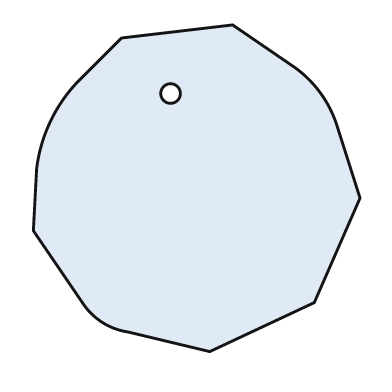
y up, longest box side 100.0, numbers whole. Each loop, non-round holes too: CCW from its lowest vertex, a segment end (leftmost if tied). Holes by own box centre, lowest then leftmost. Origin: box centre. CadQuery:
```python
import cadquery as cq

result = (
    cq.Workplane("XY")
    .moveTo(4.0, -50.0)
    .lineTo(36.0, -35.0)
    .lineTo(50.0, -3.0)
    .lineTo(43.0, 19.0)
    .threePointArc((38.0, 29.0), (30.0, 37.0))
    .lineTo(11.0, 50.0)
    .lineTo(-23.0, 46.0)
    .lineTo(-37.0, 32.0)
    .threePointArc((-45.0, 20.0), (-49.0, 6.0))
    .lineTo(-50.0, -13.0)
    .lineTo(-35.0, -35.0)
    .threePointArc((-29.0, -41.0), (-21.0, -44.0))
    .close()
    .moveTo(-8.0, 29.0)
    .circle(3.0)
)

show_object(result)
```